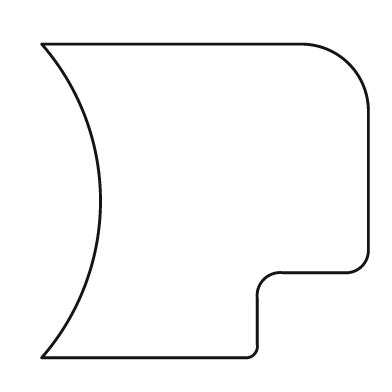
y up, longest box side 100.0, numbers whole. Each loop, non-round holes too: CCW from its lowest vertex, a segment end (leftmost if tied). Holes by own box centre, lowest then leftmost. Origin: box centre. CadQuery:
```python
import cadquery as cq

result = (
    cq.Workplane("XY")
    .moveTo(-50.0, -48.0)
    .lineTo(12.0, -48.0)
    .threePointArc((15.0, -47.0), (16.0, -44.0))
    .lineTo(16.0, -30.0)
    .threePointArc((18.0, -24.0), (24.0, -22.0))
    .lineTo(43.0, -22.0)
    .threePointArc((48.0, -20.0), (50.0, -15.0))
    .lineTo(50.0, 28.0)
    .threePointArc((44.0, 42.0), (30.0, 48.0))
    .lineTo(-50.0, 48.0)
    .threePointArc((-32.0, 0.0), (-50.0, -48.0))
    .close()
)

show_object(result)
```